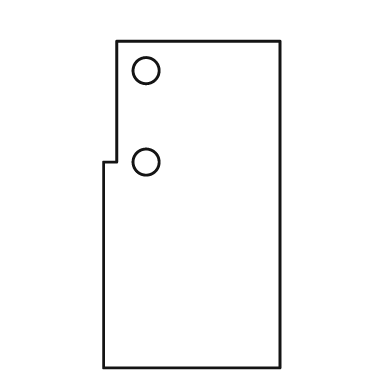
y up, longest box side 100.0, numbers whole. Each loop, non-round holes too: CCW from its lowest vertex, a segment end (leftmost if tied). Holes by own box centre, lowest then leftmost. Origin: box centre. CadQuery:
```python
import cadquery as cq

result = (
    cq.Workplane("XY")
    .moveTo(-27.0, -50.0)
    .lineTo(27.0, -50.0)
    .lineTo(27.0, 50.0)
    .lineTo(-23.0, 50.0)
    .lineTo(-23.0, 13.0)
    .lineTo(-27.0, 13.0)
    .close()
    .moveTo(-14.0, 13.0)
    .circle(4.0)
    .moveTo(-14.0, 41.0)
    .circle(4.0)
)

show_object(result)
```